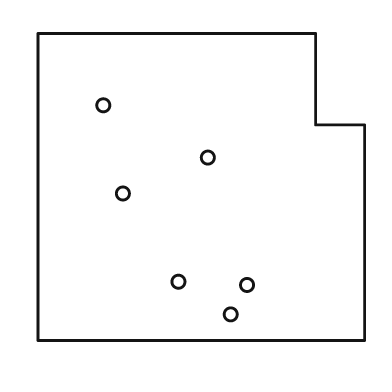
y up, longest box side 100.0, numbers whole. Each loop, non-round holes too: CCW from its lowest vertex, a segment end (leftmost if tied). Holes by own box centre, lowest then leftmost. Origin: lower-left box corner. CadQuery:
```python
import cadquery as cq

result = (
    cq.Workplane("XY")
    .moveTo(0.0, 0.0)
    .lineTo(100.0, 0.0)
    .lineTo(100.0, 66.0)
    .lineTo(85.0, 66.0)
    .lineTo(85.0, 94.0)
    .lineTo(0.0, 94.0)
    .close()
    .moveTo(59.0, 8.0)
    .circle(2.0)
    .moveTo(64.0, 17.0)
    .circle(2.0)
    .moveTo(43.0, 18.0)
    .circle(2.0)
    .moveTo(26.0, 45.0)
    .circle(2.0)
    .moveTo(52.0, 56.0)
    .circle(2.0)
    .moveTo(20.0, 72.0)
    .circle(2.0)
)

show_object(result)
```